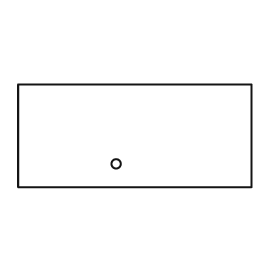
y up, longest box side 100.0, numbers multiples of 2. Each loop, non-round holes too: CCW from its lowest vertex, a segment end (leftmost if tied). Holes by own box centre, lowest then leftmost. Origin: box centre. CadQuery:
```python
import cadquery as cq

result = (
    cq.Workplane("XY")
    .moveTo(-50.0, -22.0)
    .lineTo(50.0, -22.0)
    .lineTo(50.0, 22.0)
    .lineTo(-50.0, 22.0)
    .close()
    .moveTo(-8.0, -12.0)
    .circle(2.0)
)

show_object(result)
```